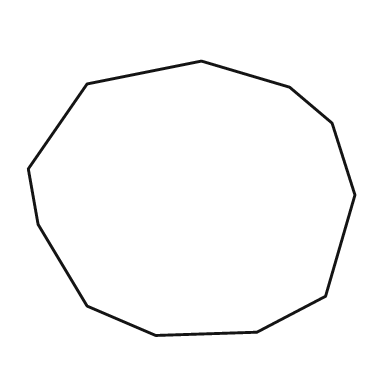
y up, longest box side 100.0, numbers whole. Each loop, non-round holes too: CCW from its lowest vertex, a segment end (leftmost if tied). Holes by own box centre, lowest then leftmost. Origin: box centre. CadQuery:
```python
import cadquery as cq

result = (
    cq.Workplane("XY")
    .moveTo(-11.0, -42.0)
    .lineTo(20.0, -41.0)
    .lineTo(41.0, -30.0)
    .lineTo(50.0, 1.0)
    .lineTo(43.0, 23.0)
    .lineTo(30.0, 34.0)
    .lineTo(3.0, 42.0)
    .lineTo(-32.0, 35.0)
    .lineTo(-50.0, 9.0)
    .lineTo(-47.0, -8.0)
    .lineTo(-32.0, -33.0)
    .close()
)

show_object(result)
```